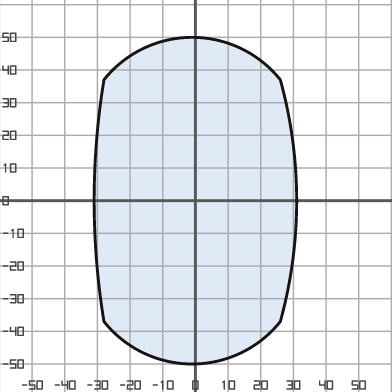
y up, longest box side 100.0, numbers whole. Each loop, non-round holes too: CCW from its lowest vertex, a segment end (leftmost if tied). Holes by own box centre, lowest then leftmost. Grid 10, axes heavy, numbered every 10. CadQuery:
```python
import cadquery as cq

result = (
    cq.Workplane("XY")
    .moveTo(-28.0, -37.0)
    .threePointArc((-1.0, -50.0), (26.0, -37.0))
    .threePointArc((31.0, 0.0), (26.0, 37.0))
    .threePointArc((-1.0, 50.0), (-28.0, 37.0))
    .threePointArc((-31.0, 0.0), (-28.0, -37.0))
    .close()
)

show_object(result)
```